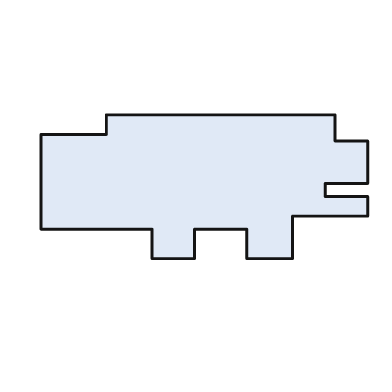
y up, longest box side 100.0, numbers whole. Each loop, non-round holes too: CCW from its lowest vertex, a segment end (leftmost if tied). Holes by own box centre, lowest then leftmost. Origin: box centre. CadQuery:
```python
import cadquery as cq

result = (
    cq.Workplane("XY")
    .moveTo(-16.0, -22.0)
    .lineTo(-3.0, -22.0)
    .lineTo(-3.0, -13.0)
    .lineTo(13.0, -13.0)
    .lineTo(13.0, -22.0)
    .lineTo(27.0, -22.0)
    .lineTo(27.0, -9.0)
    .lineTo(50.0, -9.0)
    .lineTo(50.0, -3.0)
    .lineTo(37.0, -3.0)
    .lineTo(37.0, 1.0)
    .lineTo(50.0, 1.0)
    .lineTo(50.0, 14.0)
    .lineTo(40.0, 14.0)
    .lineTo(40.0, 22.0)
    .lineTo(-30.0, 22.0)
    .lineTo(-30.0, 16.0)
    .lineTo(-50.0, 16.0)
    .lineTo(-50.0, -13.0)
    .lineTo(-16.0, -13.0)
    .close()
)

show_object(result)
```